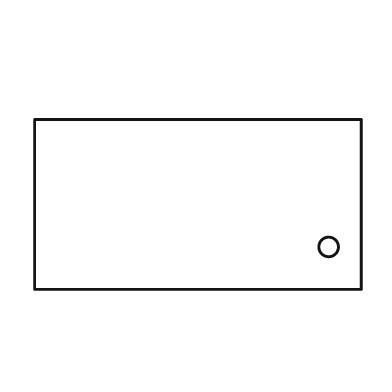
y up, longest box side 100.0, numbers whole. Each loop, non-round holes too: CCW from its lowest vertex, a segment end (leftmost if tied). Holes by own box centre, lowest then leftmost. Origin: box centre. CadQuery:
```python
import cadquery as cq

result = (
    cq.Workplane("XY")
    .moveTo(-50.0, -26.0)
    .lineTo(50.0, -26.0)
    .lineTo(50.0, 26.0)
    .lineTo(-50.0, 26.0)
    .close()
    .moveTo(40.0, -13.0)
    .circle(3.0)
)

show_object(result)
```